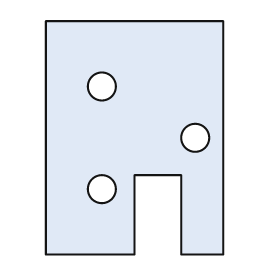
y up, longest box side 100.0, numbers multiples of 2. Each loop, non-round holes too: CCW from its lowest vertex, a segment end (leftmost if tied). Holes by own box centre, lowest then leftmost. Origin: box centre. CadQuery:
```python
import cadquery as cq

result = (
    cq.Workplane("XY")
    .moveTo(-38.0, -50.0)
    .lineTo(0.0, -50.0)
    .lineTo(0.0, -16.0)
    .lineTo(20.0, -16.0)
    .lineTo(20.0, -50.0)
    .lineTo(38.0, -50.0)
    .lineTo(38.0, 50.0)
    .lineTo(-38.0, 50.0)
    .close()
    .moveTo(-14.0, -22.0)
    .circle(6.0)
    .moveTo(26.0, 0.0)
    .circle(6.0)
    .moveTo(-14.0, 22.0)
    .circle(6.0)
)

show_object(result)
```